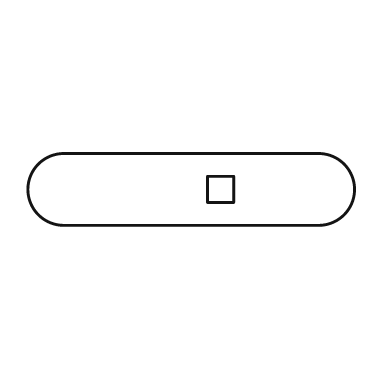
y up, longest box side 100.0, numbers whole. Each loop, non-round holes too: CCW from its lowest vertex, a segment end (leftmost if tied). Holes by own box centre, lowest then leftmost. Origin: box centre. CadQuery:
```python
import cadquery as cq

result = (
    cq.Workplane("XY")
    .moveTo(-39.0, -11.0)
    .lineTo(39.0, -11.0)
    .threePointArc((50.0, 0.0), (39.0, 11.0))
    .lineTo(-39.0, 11.0)
    .threePointArc((-50.0, 0.0), (-39.0, -11.0))
    .close()
    .moveTo(5.0, -4.0)
    .lineTo(13.0, -4.0)
    .lineTo(13.0, 4.0)
    .lineTo(5.0, 4.0)
    .close()
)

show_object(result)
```